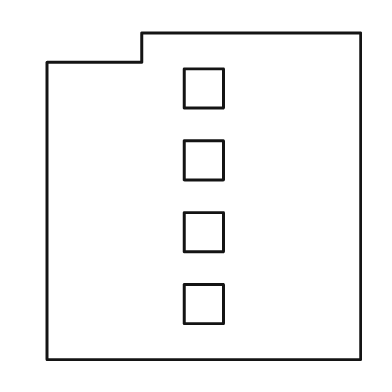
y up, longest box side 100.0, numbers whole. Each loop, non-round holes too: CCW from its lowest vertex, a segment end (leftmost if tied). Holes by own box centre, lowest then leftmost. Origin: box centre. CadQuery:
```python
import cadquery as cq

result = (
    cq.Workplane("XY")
    .moveTo(-48.0, -50.0)
    .lineTo(48.0, -50.0)
    .lineTo(48.0, 50.0)
    .lineTo(-19.0, 50.0)
    .lineTo(-19.0, 41.0)
    .lineTo(-48.0, 41.0)
    .close()
    .moveTo(-6.0, -39.0)
    .lineTo(6.0, -39.0)
    .lineTo(6.0, -27.0)
    .lineTo(-6.0, -27.0)
    .close()
    .moveTo(-6.0, -17.0)
    .lineTo(6.0, -17.0)
    .lineTo(6.0, -5.0)
    .lineTo(-6.0, -5.0)
    .close()
    .moveTo(-6.0, 5.0)
    .lineTo(6.0, 5.0)
    .lineTo(6.0, 17.0)
    .lineTo(-6.0, 17.0)
    .close()
    .moveTo(-6.0, 27.0)
    .lineTo(6.0, 27.0)
    .lineTo(6.0, 39.0)
    .lineTo(-6.0, 39.0)
    .close()
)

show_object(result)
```